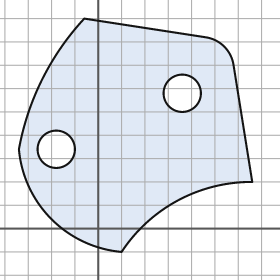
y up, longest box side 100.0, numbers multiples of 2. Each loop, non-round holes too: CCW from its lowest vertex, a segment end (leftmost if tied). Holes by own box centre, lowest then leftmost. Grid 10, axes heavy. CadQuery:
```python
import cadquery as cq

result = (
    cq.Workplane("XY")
    .moveTo(10.0, -10.0)
    .threePointArc((34.0, 12.0), (66.0, 20.0))
    .lineTo(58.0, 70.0)
    .threePointArc((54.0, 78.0), (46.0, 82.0))
    .lineTo(-6.0, 90.0)
    .threePointArc((-24.0, 64.0), (-34.0, 34.0))
    .threePointArc((-20.0, 4.0), (10.0, -10.0))
    .close()
    .moveTo(-18.0, 34.0)
    .circle(8.0)
    .moveTo(36.0, 58.0)
    .circle(8.0)
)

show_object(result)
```